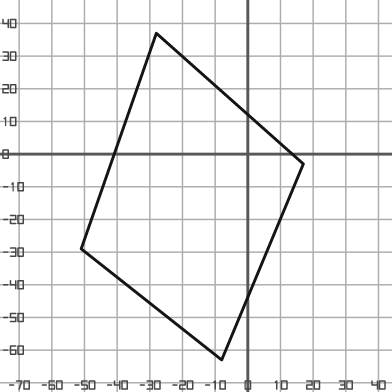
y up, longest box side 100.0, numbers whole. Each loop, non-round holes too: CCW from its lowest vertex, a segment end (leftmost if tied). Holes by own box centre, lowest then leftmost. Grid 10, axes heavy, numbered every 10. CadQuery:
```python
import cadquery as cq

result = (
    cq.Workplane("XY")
    .moveTo(-8.0, -63.0)
    .lineTo(17.0, -3.0)
    .lineTo(-28.0, 37.0)
    .lineTo(-51.0, -29.0)
    .close()
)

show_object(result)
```